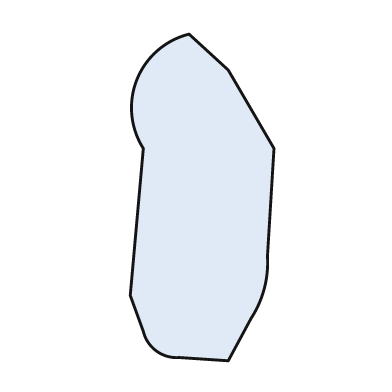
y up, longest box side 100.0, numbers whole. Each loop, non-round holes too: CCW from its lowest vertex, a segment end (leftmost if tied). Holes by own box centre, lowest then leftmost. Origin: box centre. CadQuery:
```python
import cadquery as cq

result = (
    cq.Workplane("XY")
    .moveTo(8.0, -50.0)
    .lineTo(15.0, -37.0)
    .threePointArc((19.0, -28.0), (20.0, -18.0))
    .lineTo(22.0, 15.0)
    .lineTo(8.0, 39.0)
    .lineTo(-4.0, 50.0)
    .threePointArc((-20.0, 36.0), (-18.0, 15.0))
    .lineTo(-22.0, -30.0)
    .lineTo(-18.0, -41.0)
    .threePointArc((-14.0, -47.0), (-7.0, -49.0))
    .close()
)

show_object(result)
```